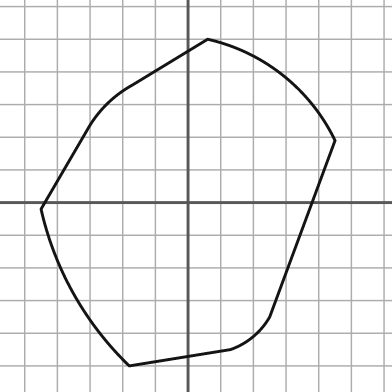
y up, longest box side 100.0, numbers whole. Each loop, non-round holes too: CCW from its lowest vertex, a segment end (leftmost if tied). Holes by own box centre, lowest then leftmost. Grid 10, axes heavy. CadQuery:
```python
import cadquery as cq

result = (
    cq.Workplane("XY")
    .moveTo(-18.0, -50.0)
    .lineTo(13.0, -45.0)
    .threePointArc((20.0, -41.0), (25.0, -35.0))
    .lineTo(45.0, 19.0)
    .threePointArc((29.0, 39.0), (6.0, 50.0))
    .lineTo(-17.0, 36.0)
    .threePointArc((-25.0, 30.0), (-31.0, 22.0))
    .lineTo(-45.0, -2.0)
    .threePointArc((-35.0, -28.0), (-18.0, -50.0))
    .close()
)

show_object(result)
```